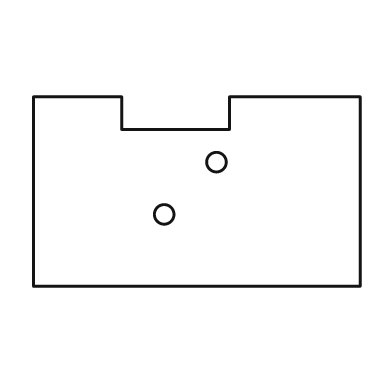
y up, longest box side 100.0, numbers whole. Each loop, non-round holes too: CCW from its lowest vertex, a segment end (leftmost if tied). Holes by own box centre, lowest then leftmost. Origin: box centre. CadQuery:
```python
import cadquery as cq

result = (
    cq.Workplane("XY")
    .moveTo(-50.0, -29.0)
    .lineTo(50.0, -29.0)
    .lineTo(50.0, 29.0)
    .lineTo(10.0, 29.0)
    .lineTo(10.0, 19.0)
    .lineTo(-23.0, 19.0)
    .lineTo(-23.0, 29.0)
    .lineTo(-50.0, 29.0)
    .close()
    .moveTo(-10.0, -7.0)
    .circle(3.0)
    .moveTo(6.0, 9.0)
    .circle(3.0)
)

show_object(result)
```